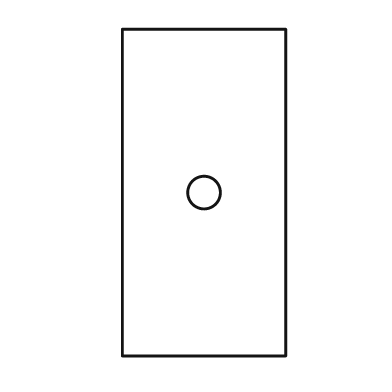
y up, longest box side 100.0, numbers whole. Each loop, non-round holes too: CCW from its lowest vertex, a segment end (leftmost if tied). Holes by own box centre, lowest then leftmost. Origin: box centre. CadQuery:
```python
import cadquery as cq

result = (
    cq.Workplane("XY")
    .moveTo(-25.0, -50.0)
    .lineTo(25.0, -50.0)
    .lineTo(25.0, 50.0)
    .lineTo(-25.0, 50.0)
    .close()
    .moveTo(0.0, 0.0)
    .circle(5.0)
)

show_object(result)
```